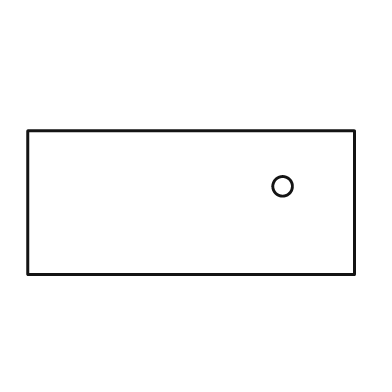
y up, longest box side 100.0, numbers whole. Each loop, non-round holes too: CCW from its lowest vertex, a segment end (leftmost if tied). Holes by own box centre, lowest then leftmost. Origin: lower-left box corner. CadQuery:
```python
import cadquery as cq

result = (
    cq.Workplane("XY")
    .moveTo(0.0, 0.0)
    .lineTo(100.0, 0.0)
    .lineTo(100.0, 44.0)
    .lineTo(0.0, 44.0)
    .close()
    .moveTo(78.0, 27.0)
    .circle(3.0)
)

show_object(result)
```